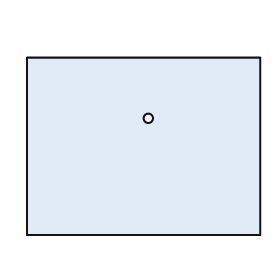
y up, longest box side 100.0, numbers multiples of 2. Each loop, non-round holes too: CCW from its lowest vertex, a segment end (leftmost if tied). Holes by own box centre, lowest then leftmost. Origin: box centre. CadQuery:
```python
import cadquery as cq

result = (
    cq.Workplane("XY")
    .moveTo(-50.0, -38.0)
    .lineTo(50.0, -38.0)
    .lineTo(50.0, 38.0)
    .lineTo(-50.0, 38.0)
    .close()
    .moveTo(2.0, 12.0)
    .circle(2.0)
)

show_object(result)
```